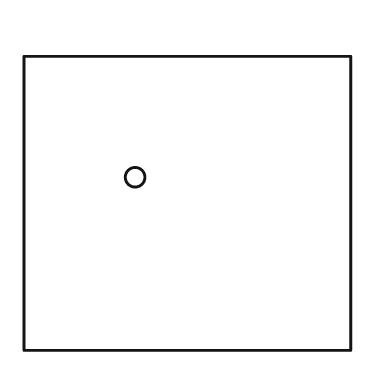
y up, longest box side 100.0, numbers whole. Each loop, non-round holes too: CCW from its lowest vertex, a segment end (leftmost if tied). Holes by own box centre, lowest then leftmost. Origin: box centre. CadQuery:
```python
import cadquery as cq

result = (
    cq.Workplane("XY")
    .moveTo(-50.0, -45.0)
    .lineTo(50.0, -45.0)
    .lineTo(50.0, 45.0)
    .lineTo(-50.0, 45.0)
    .close()
    .moveTo(-16.0, 8.0)
    .circle(3.0)
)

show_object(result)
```